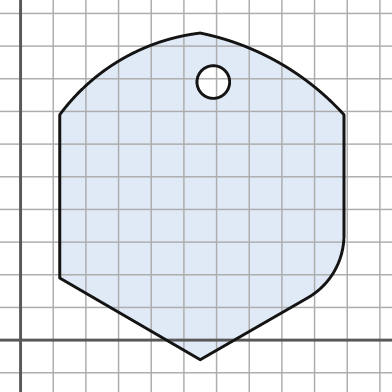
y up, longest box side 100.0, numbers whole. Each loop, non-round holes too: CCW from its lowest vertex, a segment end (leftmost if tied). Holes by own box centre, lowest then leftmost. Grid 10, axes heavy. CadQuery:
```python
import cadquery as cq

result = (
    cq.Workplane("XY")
    .moveTo(55.0, -6.0)
    .lineTo(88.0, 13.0)
    .threePointArc((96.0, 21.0), (99.0, 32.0))
    .lineTo(99.0, 69.0)
    .threePointArc((79.0, 85.0), (55.0, 94.0))
    .threePointArc((31.0, 86.0), (12.0, 69.0))
    .lineTo(12.0, 19.0)
    .close()
    .moveTo(59.0, 79.0)
    .circle(5.0)
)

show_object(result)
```